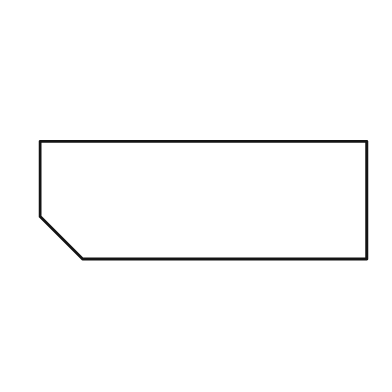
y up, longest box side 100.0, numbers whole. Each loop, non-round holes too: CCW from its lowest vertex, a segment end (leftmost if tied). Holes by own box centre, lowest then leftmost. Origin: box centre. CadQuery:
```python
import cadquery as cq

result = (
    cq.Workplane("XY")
    .moveTo(-37.0, -18.0)
    .lineTo(50.0, -18.0)
    .lineTo(50.0, 18.0)
    .lineTo(-50.0, 18.0)
    .lineTo(-50.0, -5.0)
    .close()
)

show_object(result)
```